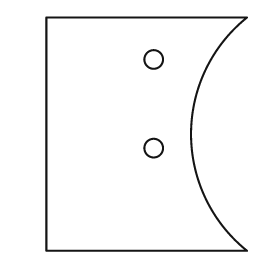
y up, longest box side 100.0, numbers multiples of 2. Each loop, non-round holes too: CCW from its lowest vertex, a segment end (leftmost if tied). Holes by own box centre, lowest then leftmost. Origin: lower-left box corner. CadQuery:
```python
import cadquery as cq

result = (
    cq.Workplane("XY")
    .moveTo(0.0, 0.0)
    .lineTo(86.0, 0.0)
    .threePointArc((62.0, 50.0), (86.0, 100.0))
    .lineTo(0.0, 100.0)
    .close()
    .moveTo(46.0, 44.0)
    .circle(4.0)
    .moveTo(46.0, 82.0)
    .circle(4.0)
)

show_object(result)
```